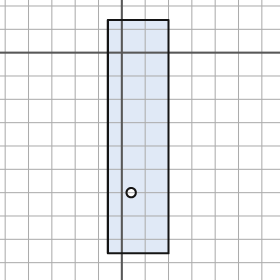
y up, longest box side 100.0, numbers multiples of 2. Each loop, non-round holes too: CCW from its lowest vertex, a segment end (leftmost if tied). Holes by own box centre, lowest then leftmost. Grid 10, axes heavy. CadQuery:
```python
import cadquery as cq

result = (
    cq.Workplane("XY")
    .moveTo(-6.0, -86.0)
    .lineTo(20.0, -86.0)
    .lineTo(20.0, 14.0)
    .lineTo(-6.0, 14.0)
    .close()
    .moveTo(4.0, -60.0)
    .circle(2.0)
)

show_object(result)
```